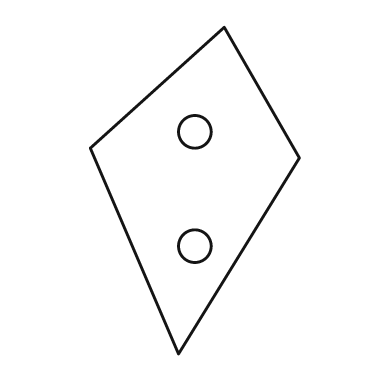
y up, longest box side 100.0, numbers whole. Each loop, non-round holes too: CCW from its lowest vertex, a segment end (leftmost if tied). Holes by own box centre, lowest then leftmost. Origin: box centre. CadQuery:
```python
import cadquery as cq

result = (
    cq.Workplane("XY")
    .moveTo(-5.0, -50.0)
    .lineTo(32.0, 10.0)
    .lineTo(9.0, 50.0)
    .lineTo(-32.0, 13.0)
    .close()
    .moveTo(0.0, -17.0)
    .circle(5.0)
    .moveTo(0.0, 18.0)
    .circle(5.0)
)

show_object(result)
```